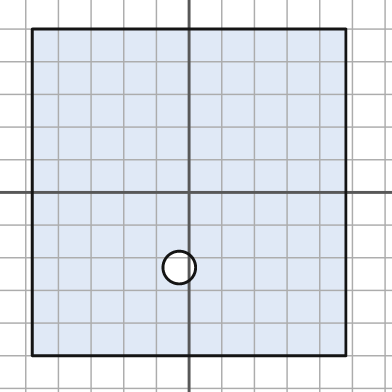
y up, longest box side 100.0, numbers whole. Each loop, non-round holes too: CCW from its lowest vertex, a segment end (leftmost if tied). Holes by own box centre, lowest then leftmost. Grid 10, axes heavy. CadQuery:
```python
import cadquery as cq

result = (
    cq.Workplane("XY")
    .moveTo(-48.0, -50.0)
    .lineTo(48.0, -50.0)
    .lineTo(48.0, 50.0)
    .lineTo(-48.0, 50.0)
    .close()
    .moveTo(-3.0, -23.0)
    .circle(5.0)
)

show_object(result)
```